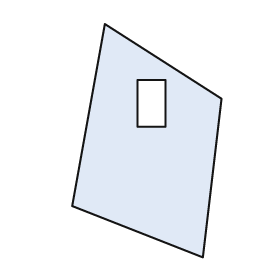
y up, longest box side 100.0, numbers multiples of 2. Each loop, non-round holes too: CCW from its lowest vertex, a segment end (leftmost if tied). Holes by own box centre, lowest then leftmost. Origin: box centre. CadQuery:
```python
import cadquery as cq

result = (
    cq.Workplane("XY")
    .moveTo(24.0, -50.0)
    .lineTo(32.0, 18.0)
    .lineTo(-18.0, 50.0)
    .lineTo(-32.0, -28.0)
    .close()
    .moveTo(-4.0, 6.0)
    .lineTo(8.0, 6.0)
    .lineTo(8.0, 26.0)
    .lineTo(-4.0, 26.0)
    .close()
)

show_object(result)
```